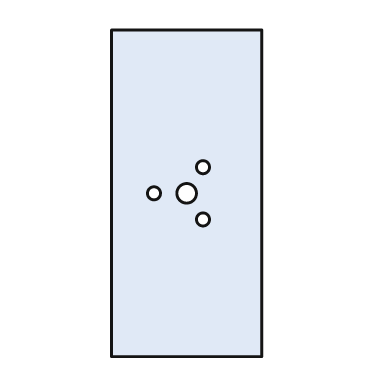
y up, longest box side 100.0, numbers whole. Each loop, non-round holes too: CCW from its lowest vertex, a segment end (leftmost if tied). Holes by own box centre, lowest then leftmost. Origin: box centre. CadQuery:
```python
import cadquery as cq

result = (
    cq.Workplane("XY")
    .moveTo(-23.0, -50.0)
    .lineTo(23.0, -50.0)
    .lineTo(23.0, 50.0)
    .lineTo(-23.0, 50.0)
    .close()
    .moveTo(5.0, -8.0)
    .circle(2.0)
    .moveTo(-10.0, 0.0)
    .circle(2.0)
    .moveTo(0.0, 0.0)
    .circle(3.0)
    .moveTo(5.0, 8.0)
    .circle(2.0)
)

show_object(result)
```